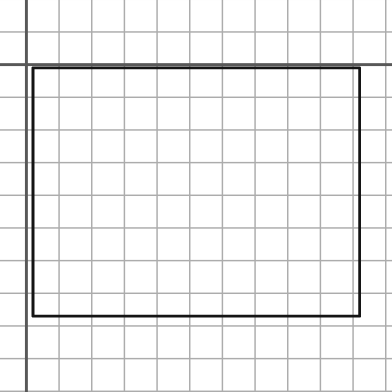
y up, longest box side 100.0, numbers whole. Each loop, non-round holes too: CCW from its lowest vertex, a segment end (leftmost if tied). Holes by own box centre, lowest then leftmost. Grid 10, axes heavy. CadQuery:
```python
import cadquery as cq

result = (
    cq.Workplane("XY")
    .moveTo(2.0, -77.0)
    .lineTo(102.0, -77.0)
    .lineTo(102.0, -1.0)
    .lineTo(2.0, -1.0)
    .close()
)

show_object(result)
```